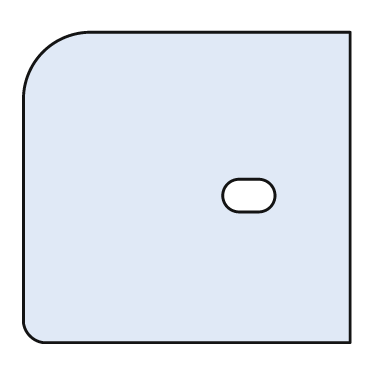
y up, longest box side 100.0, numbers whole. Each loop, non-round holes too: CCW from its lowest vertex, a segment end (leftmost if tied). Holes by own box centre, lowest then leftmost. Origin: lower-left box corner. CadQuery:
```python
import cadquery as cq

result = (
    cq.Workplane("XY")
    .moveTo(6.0, 0.0)
    .lineTo(100.0, 0.0)
    .lineTo(100.0, 95.0)
    .lineTo(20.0, 95.0)
    .threePointArc((6.0, 89.0), (0.0, 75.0))
    .lineTo(0.0, 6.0)
    .threePointArc((2.0, 2.0), (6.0, 0.0))
    .close()
    .moveTo(66.0, 40.0)
    .lineTo(72.0, 40.0)
    .threePointArc((77.0, 45.0), (72.0, 50.0))
    .lineTo(66.0, 50.0)
    .threePointArc((61.0, 45.0), (66.0, 40.0))
    .close()
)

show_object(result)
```